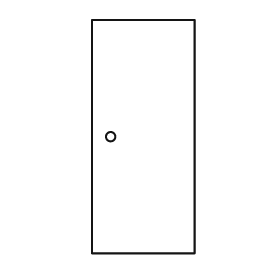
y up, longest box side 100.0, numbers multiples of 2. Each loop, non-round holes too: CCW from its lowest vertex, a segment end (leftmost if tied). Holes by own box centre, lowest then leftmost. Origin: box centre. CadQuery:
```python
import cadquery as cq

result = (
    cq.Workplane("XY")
    .moveTo(-22.0, -50.0)
    .lineTo(22.0, -50.0)
    .lineTo(22.0, 50.0)
    .lineTo(-22.0, 50.0)
    .close()
    .moveTo(-14.0, 0.0)
    .circle(2.0)
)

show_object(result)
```